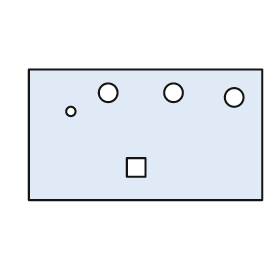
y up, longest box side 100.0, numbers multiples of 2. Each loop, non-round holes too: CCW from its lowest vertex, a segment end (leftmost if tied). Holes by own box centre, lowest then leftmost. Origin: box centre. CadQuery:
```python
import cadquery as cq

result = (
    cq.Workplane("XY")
    .moveTo(-50.0, -28.0)
    .lineTo(50.0, -28.0)
    .lineTo(50.0, 28.0)
    .lineTo(-50.0, 28.0)
    .close()
    .moveTo(-8.0, -18.0)
    .lineTo(0.0, -18.0)
    .lineTo(0.0, -10.0)
    .lineTo(-8.0, -10.0)
    .close()
    .moveTo(-32.0, 10.0)
    .circle(2.0)
    .moveTo(38.0, 16.0)
    .circle(4.0)
    .moveTo(-16.0, 18.0)
    .circle(4.0)
    .moveTo(12.0, 18.0)
    .circle(4.0)
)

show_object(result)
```